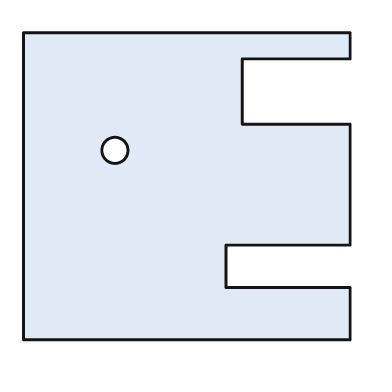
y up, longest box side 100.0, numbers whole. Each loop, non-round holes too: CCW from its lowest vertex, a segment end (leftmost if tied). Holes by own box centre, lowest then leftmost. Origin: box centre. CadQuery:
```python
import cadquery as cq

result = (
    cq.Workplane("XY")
    .moveTo(-50.0, -47.0)
    .lineTo(50.0, -47.0)
    .lineTo(50.0, -31.0)
    .lineTo(12.0, -31.0)
    .lineTo(12.0, -18.0)
    .lineTo(50.0, -18.0)
    .lineTo(50.0, 19.0)
    .lineTo(17.0, 19.0)
    .lineTo(17.0, 39.0)
    .lineTo(50.0, 39.0)
    .lineTo(50.0, 47.0)
    .lineTo(-50.0, 47.0)
    .close()
    .moveTo(-22.0, 11.0)
    .circle(4.0)
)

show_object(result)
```